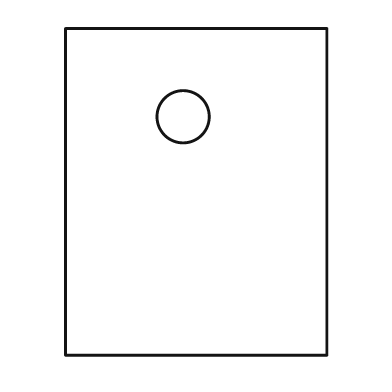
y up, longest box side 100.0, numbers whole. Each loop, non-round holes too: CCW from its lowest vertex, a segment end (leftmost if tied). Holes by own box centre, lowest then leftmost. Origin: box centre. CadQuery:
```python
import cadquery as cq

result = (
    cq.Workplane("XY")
    .moveTo(-40.0, -50.0)
    .lineTo(40.0, -50.0)
    .lineTo(40.0, 50.0)
    .lineTo(-40.0, 50.0)
    .close()
    .moveTo(-4.0, 23.0)
    .circle(8.0)
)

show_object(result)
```